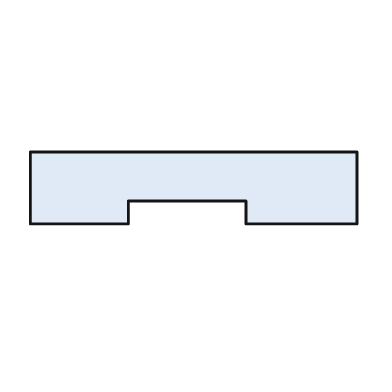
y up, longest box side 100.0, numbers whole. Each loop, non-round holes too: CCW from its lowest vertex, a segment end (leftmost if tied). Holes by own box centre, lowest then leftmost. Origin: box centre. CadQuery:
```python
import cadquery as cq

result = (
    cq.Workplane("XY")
    .moveTo(-50.0, -11.0)
    .lineTo(-20.0, -11.0)
    .lineTo(-20.0, -4.0)
    .lineTo(16.0, -4.0)
    .lineTo(16.0, -11.0)
    .lineTo(50.0, -11.0)
    .lineTo(50.0, 11.0)
    .lineTo(-50.0, 11.0)
    .close()
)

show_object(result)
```